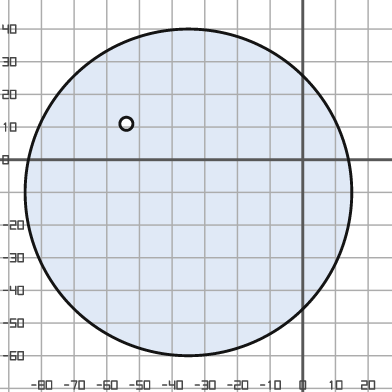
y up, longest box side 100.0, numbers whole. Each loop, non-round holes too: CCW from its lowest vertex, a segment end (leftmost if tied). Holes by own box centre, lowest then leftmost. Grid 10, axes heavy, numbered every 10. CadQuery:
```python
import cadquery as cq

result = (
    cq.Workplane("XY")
    .moveTo(-35.0, -10.0)
    .circle(50.0)
    .moveTo(-54.0, 11.0)
    .circle(2.0)
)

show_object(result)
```